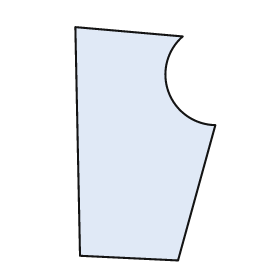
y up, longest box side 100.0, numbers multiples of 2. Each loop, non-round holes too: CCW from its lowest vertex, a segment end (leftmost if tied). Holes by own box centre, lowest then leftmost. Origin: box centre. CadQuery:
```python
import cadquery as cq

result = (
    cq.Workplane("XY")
    .moveTo(14.0, -50.0)
    .lineTo(30.0, 8.0)
    .threePointArc((10.0, 22.0), (16.0, 46.0))
    .lineTo(-30.0, 50.0)
    .lineTo(-28.0, -48.0)
    .close()
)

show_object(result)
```